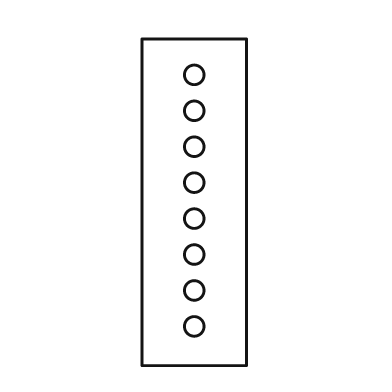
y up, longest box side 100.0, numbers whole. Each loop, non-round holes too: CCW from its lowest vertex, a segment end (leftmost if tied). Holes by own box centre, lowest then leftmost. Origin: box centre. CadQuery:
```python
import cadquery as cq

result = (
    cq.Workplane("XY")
    .moveTo(-16.0, -50.0)
    .lineTo(16.0, -50.0)
    .lineTo(16.0, 50.0)
    .lineTo(-16.0, 50.0)
    .close()
    .moveTo(0.0, -38.0)
    .circle(3.0)
    .moveTo(0.0, -27.0)
    .circle(3.0)
    .moveTo(0.0, -16.0)
    .circle(3.0)
    .moveTo(0.0, -5.0)
    .circle(3.0)
    .moveTo(0.0, 6.0)
    .circle(3.0)
    .moveTo(0.0, 17.0)
    .circle(3.0)
    .moveTo(0.0, 28.0)
    .circle(3.0)
    .moveTo(0.0, 39.0)
    .circle(3.0)
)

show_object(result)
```